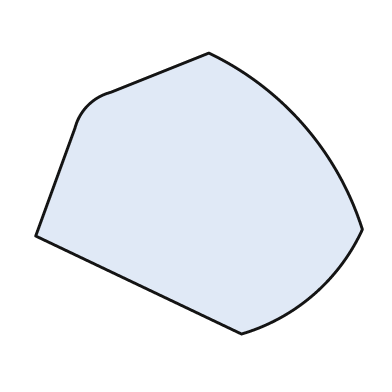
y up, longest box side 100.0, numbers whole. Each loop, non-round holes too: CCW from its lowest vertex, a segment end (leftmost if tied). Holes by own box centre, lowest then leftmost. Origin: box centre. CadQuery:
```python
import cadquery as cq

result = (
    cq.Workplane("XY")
    .moveTo(13.0, -43.0)
    .threePointArc((35.0, -31.0), (50.0, -11.0))
    .threePointArc((32.0, 21.0), (3.0, 43.0))
    .lineTo(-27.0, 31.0)
    .threePointArc((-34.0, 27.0), (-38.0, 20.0))
    .lineTo(-50.0, -13.0)
    .close()
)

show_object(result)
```